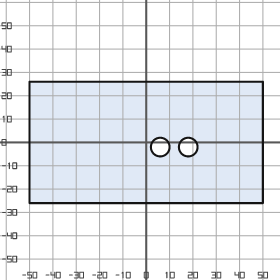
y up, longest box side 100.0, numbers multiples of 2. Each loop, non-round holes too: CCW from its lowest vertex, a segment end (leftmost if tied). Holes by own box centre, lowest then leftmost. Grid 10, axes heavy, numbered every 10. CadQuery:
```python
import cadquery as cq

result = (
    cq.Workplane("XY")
    .moveTo(-50.0, -26.0)
    .lineTo(50.0, -26.0)
    .lineTo(50.0, 26.0)
    .lineTo(-50.0, 26.0)
    .close()
    .moveTo(6.0, -2.0)
    .circle(4.0)
    .moveTo(18.0, -2.0)
    .circle(4.0)
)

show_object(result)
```